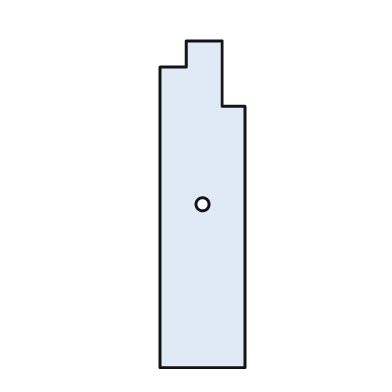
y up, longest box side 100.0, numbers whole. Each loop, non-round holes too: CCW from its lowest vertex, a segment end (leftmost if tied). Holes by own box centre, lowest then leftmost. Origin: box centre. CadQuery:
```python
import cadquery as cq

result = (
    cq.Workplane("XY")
    .moveTo(-13.0, -50.0)
    .lineTo(13.0, -50.0)
    .lineTo(13.0, 30.0)
    .lineTo(6.0, 30.0)
    .lineTo(6.0, 50.0)
    .lineTo(-5.0, 50.0)
    .lineTo(-5.0, 42.0)
    .lineTo(-13.0, 42.0)
    .close()
    .moveTo(0.0, 0.0)
    .circle(2.0)
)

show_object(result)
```